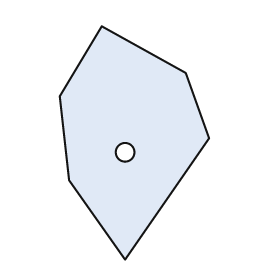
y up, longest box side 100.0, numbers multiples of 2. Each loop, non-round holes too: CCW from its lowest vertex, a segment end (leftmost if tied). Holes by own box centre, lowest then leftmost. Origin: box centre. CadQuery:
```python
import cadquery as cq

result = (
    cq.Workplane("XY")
    .moveTo(-4.0, -50.0)
    .lineTo(32.0, 2.0)
    .lineTo(22.0, 30.0)
    .lineTo(-14.0, 50.0)
    .lineTo(-32.0, 20.0)
    .lineTo(-28.0, -16.0)
    .close()
    .moveTo(-4.0, -4.0)
    .circle(4.0)
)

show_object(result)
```